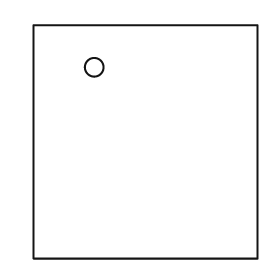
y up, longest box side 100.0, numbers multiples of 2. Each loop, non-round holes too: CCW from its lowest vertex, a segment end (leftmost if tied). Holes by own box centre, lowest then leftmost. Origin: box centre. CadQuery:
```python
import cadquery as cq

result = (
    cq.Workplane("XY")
    .moveTo(-48.0, -50.0)
    .lineTo(48.0, -50.0)
    .lineTo(48.0, 50.0)
    .lineTo(-48.0, 50.0)
    .close()
    .moveTo(-22.0, 32.0)
    .circle(4.0)
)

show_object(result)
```